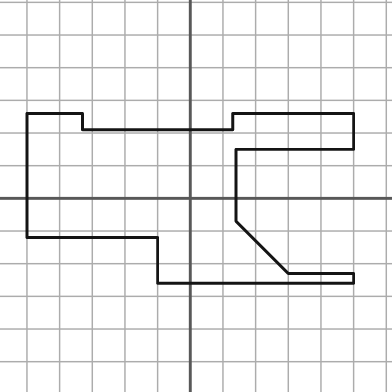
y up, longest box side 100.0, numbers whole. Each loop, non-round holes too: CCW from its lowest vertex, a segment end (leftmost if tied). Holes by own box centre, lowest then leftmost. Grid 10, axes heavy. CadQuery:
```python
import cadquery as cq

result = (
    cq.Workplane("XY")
    .moveTo(-10.0, -26.0)
    .lineTo(50.0, -26.0)
    .lineTo(50.0, -23.0)
    .lineTo(30.0, -23.0)
    .lineTo(14.0, -7.0)
    .lineTo(14.0, 15.0)
    .lineTo(50.0, 15.0)
    .lineTo(50.0, 26.0)
    .lineTo(13.0, 26.0)
    .lineTo(13.0, 21.0)
    .lineTo(-33.0, 21.0)
    .lineTo(-33.0, 26.0)
    .lineTo(-50.0, 26.0)
    .lineTo(-50.0, -12.0)
    .lineTo(-10.0, -12.0)
    .close()
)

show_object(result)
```